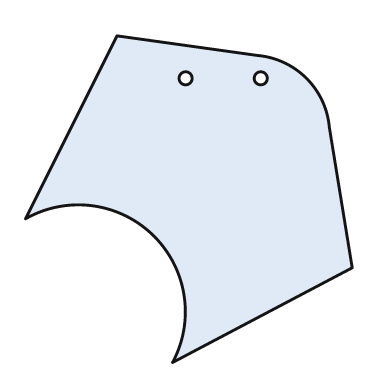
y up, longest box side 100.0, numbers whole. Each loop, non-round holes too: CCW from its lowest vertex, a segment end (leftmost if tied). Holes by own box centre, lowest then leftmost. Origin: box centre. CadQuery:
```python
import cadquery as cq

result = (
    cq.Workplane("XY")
    .moveTo(-5.0, -50.0)
    .lineTo(50.0, -21.0)
    .lineTo(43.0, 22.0)
    .threePointArc((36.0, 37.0), (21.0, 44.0))
    .lineTo(-22.0, 50.0)
    .lineTo(-50.0, -6.0)
    .threePointArc((-11.0, -11.0), (-5.0, -50.0))
    .close()
    .moveTo(-1.0, 37.0)
    .circle(2.0)
    .moveTo(22.0, 37.0)
    .circle(2.0)
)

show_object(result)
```